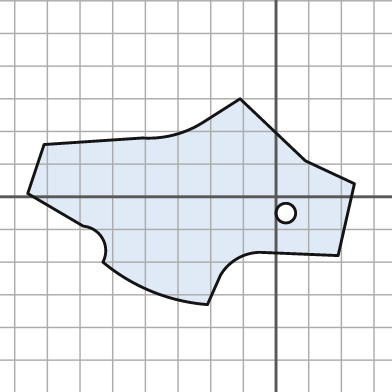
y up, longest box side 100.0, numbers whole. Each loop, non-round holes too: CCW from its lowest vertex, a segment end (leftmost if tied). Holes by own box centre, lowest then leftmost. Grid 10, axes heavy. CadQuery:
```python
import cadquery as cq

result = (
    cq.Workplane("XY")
    .moveTo(-21.0, -33.0)
    .lineTo(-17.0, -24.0)
    .threePointArc((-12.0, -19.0), (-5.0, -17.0))
    .lineTo(19.0, -18.0)
    .lineTo(24.0, 4.0)
    .lineTo(9.0, 11.0)
    .lineTo(-11.0, 30.0)
    .lineTo(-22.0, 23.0)
    .threePointArc((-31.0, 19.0), (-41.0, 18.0))
    .lineTo(-71.0, 16.0)
    .lineTo(-76.0, 1.0)
    .lineTo(-59.0, -9.0)
    .threePointArc((-53.0, -13.0), (-53.0, -20.0))
    .threePointArc((-38.0, -29.0), (-21.0, -33.0))
    .close()
    .moveTo(3.0, -5.0)
    .circle(3.0)
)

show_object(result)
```